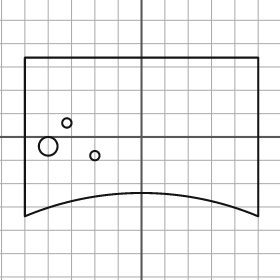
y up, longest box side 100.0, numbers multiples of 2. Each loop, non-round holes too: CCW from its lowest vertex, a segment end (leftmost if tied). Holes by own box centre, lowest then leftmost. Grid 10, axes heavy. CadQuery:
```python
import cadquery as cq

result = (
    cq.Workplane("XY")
    .moveTo(-50.0, -34.0)
    .threePointArc((0.0, -24.0), (50.0, -34.0))
    .lineTo(50.0, 34.0)
    .lineTo(-50.0, 34.0)
    .close()
    .moveTo(-20.0, -8.0)
    .circle(2.0)
    .moveTo(-40.0, -4.0)
    .circle(4.0)
    .moveTo(-32.0, 6.0)
    .circle(2.0)
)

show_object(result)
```